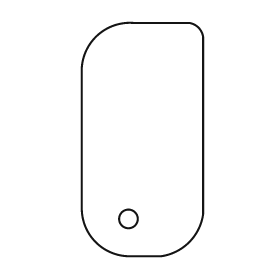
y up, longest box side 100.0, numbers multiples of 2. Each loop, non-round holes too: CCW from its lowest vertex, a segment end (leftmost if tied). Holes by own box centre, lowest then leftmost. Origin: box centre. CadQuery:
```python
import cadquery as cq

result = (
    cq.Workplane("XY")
    .moveTo(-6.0, -50.0)
    .lineTo(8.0, -50.0)
    .threePointArc((20.0, -44.0), (26.0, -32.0))
    .lineTo(26.0, 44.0)
    .threePointArc((24.0, 48.0), (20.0, 50.0))
    .lineTo(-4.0, 50.0)
    .threePointArc((-20.0, 44.0), (-26.0, 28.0))
    .lineTo(-26.0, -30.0)
    .threePointArc((-20.0, -44.0), (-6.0, -50.0))
    .close()
    .moveTo(-6.0, -34.0)
    .circle(4.0)
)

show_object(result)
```